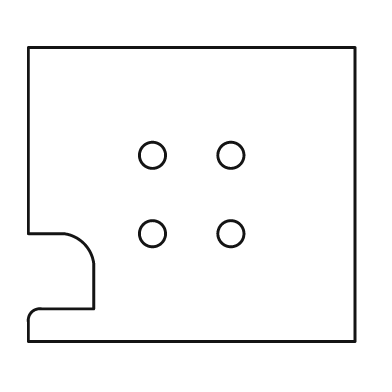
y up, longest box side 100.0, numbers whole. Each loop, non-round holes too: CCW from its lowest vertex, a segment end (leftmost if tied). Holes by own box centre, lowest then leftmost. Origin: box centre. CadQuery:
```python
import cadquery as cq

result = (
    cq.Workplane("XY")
    .moveTo(-50.0, -45.0)
    .lineTo(50.0, -45.0)
    .lineTo(50.0, 45.0)
    .lineTo(-50.0, 45.0)
    .lineTo(-50.0, -12.0)
    .lineTo(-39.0, -12.0)
    .threePointArc((-33.0, -15.0), (-30.0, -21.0))
    .lineTo(-30.0, -35.0)
    .lineTo(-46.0, -35.0)
    .threePointArc((-49.0, -36.0), (-50.0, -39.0))
    .close()
    .moveTo(-12.0, -12.0)
    .circle(4.0)
    .moveTo(12.0, -12.0)
    .circle(4.0)
    .moveTo(-12.0, 12.0)
    .circle(4.0)
    .moveTo(12.0, 12.0)
    .circle(4.0)
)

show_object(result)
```